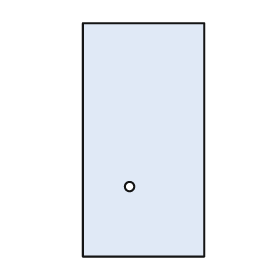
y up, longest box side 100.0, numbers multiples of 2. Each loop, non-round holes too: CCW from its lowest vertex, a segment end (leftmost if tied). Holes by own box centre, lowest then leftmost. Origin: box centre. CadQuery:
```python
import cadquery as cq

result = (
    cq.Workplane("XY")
    .moveTo(-26.0, -50.0)
    .lineTo(26.0, -50.0)
    .lineTo(26.0, 50.0)
    .lineTo(-26.0, 50.0)
    .close()
    .moveTo(-6.0, -20.0)
    .circle(2.0)
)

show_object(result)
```